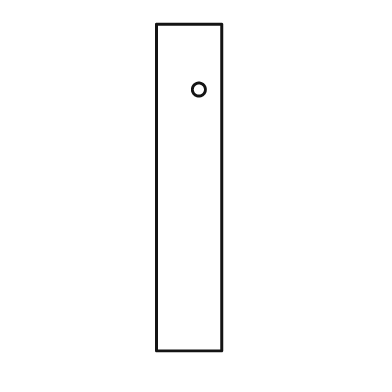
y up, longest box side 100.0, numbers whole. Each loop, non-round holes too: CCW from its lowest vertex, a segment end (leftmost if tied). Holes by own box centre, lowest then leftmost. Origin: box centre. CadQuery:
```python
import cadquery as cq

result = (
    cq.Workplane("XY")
    .moveTo(-10.0, -50.0)
    .lineTo(10.0, -50.0)
    .lineTo(10.0, 50.0)
    .lineTo(-10.0, 50.0)
    .close()
    .moveTo(3.0, 30.0)
    .circle(2.0)
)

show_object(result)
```